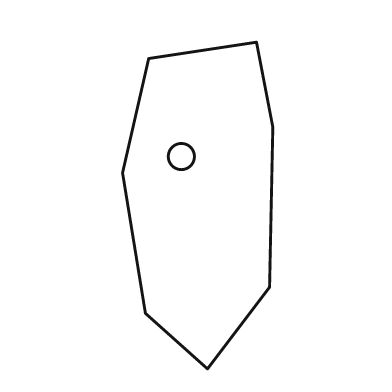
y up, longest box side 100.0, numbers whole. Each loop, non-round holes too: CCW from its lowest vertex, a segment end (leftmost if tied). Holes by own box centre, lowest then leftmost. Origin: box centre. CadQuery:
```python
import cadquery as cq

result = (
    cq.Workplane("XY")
    .moveTo(3.0, -50.0)
    .lineTo(22.0, -25.0)
    .lineTo(23.0, 24.0)
    .lineTo(18.0, 50.0)
    .lineTo(-15.0, 45.0)
    .lineTo(-23.0, 10.0)
    .lineTo(-16.0, -33.0)
    .close()
    .moveTo(-5.0, 15.0)
    .circle(4.0)
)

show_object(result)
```